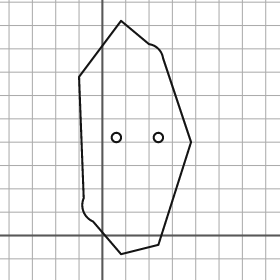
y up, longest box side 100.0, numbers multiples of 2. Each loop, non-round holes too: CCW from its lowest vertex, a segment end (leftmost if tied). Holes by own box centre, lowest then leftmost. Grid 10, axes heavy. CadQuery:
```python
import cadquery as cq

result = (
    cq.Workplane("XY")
    .moveTo(8.0, -8.0)
    .lineTo(24.0, -4.0)
    .lineTo(38.0, 40.0)
    .lineTo(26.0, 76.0)
    .threePointArc((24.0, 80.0), (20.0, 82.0))
    .lineTo(8.0, 92.0)
    .lineTo(-10.0, 68.0)
    .lineTo(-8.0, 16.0)
    .threePointArc((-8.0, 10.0), (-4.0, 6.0))
    .close()
    .moveTo(6.0, 42.0)
    .circle(2.0)
    .moveTo(24.0, 42.0)
    .circle(2.0)
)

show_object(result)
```